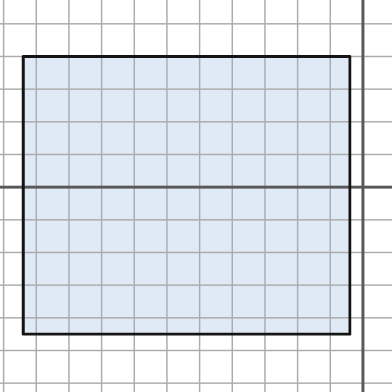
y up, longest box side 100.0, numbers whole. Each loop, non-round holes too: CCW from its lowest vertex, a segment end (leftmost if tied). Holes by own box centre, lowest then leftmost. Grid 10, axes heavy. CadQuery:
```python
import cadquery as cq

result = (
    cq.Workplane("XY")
    .moveTo(-104.0, -45.0)
    .lineTo(-4.0, -45.0)
    .lineTo(-4.0, 40.0)
    .lineTo(-104.0, 40.0)
    .close()
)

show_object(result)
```